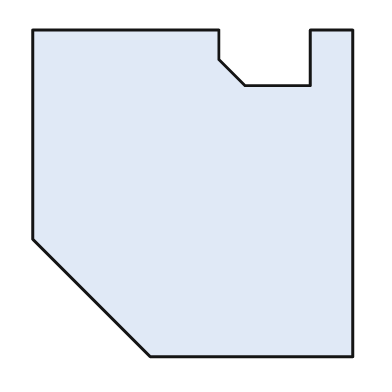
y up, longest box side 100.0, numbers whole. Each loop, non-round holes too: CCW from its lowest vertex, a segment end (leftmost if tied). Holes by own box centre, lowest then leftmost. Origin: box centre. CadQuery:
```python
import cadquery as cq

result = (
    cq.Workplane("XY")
    .moveTo(-13.0, -50.0)
    .lineTo(49.0, -50.0)
    .lineTo(49.0, 50.0)
    .lineTo(36.0, 50.0)
    .lineTo(36.0, 33.0)
    .lineTo(16.0, 33.0)
    .lineTo(8.0, 41.0)
    .lineTo(8.0, 50.0)
    .lineTo(-49.0, 50.0)
    .lineTo(-49.0, -14.0)
    .close()
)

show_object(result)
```